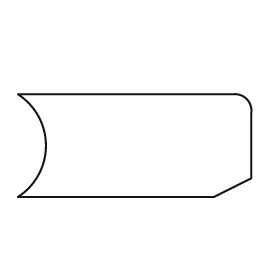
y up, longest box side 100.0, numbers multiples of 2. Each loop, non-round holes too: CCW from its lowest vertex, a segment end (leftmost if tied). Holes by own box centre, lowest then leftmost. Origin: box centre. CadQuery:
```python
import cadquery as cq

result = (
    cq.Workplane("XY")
    .moveTo(-50.0, -22.0)
    .lineTo(34.0, -22.0)
    .lineTo(50.0, -14.0)
    .lineTo(50.0, 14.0)
    .threePointArc((48.0, 20.0), (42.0, 22.0))
    .lineTo(-50.0, 22.0)
    .threePointArc((-38.0, 0.0), (-50.0, -22.0))
    .close()
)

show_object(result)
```